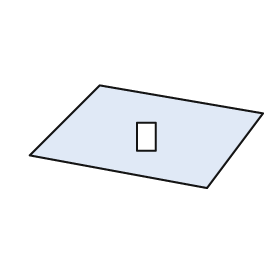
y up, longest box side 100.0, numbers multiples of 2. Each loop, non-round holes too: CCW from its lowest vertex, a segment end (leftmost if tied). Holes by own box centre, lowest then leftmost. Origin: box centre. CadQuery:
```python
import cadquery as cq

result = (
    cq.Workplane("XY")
    .moveTo(26.0, -22.0)
    .lineTo(50.0, 10.0)
    .lineTo(-20.0, 22.0)
    .lineTo(-50.0, -8.0)
    .close()
    .moveTo(-4.0, -6.0)
    .lineTo(4.0, -6.0)
    .lineTo(4.0, 6.0)
    .lineTo(-4.0, 6.0)
    .close()
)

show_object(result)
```